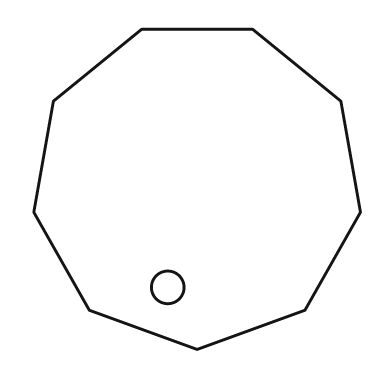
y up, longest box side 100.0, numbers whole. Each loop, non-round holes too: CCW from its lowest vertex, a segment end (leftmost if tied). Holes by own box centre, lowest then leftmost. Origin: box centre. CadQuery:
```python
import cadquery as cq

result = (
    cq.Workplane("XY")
    .moveTo(0.0, -49.0)
    .lineTo(33.0, -37.0)
    .lineTo(50.0, -7.0)
    .lineTo(44.0, 27.0)
    .lineTo(17.0, 49.0)
    .lineTo(-17.0, 49.0)
    .lineTo(-44.0, 27.0)
    .lineTo(-50.0, -7.0)
    .lineTo(-33.0, -37.0)
    .close()
    .moveTo(-9.0, -30.0)
    .circle(5.0)
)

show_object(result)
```